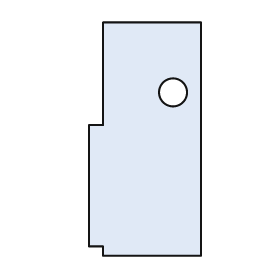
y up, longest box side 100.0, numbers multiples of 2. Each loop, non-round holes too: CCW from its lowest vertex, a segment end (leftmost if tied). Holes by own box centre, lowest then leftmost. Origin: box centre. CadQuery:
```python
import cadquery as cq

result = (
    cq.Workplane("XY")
    .moveTo(-18.0, -50.0)
    .lineTo(24.0, -50.0)
    .lineTo(24.0, 50.0)
    .lineTo(-18.0, 50.0)
    .lineTo(-18.0, 6.0)
    .lineTo(-24.0, 6.0)
    .lineTo(-24.0, -46.0)
    .lineTo(-18.0, -46.0)
    .close()
    .moveTo(12.0, 20.0)
    .circle(6.0)
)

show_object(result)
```